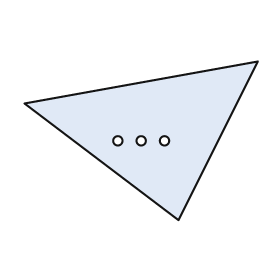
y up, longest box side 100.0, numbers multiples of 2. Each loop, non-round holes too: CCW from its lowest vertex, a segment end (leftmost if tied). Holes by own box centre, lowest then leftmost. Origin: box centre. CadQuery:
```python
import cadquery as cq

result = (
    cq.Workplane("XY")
    .moveTo(16.0, -34.0)
    .lineTo(50.0, 34.0)
    .lineTo(-50.0, 16.0)
    .close()
    .moveTo(-10.0, 0.0)
    .circle(2.0)
    .moveTo(0.0, 0.0)
    .circle(2.0)
    .moveTo(10.0, 0.0)
    .circle(2.0)
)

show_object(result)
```